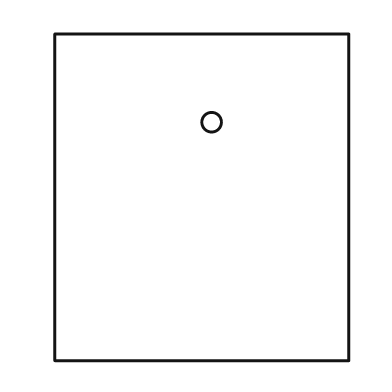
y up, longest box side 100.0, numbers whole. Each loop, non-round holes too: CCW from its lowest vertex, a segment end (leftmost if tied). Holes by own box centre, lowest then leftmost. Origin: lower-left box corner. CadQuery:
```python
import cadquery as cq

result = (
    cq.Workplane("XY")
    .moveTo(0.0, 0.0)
    .lineTo(90.0, 0.0)
    .lineTo(90.0, 100.0)
    .lineTo(0.0, 100.0)
    .close()
    .moveTo(48.0, 73.0)
    .circle(3.0)
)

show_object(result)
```